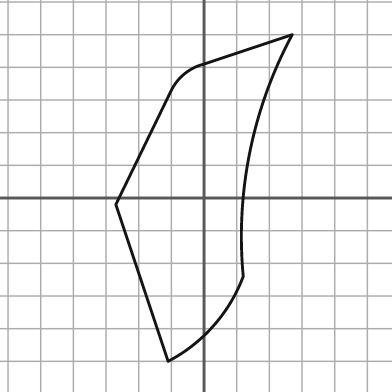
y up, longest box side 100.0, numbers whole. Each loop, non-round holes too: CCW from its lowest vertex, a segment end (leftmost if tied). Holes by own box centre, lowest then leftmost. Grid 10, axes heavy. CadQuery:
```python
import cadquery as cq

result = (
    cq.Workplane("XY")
    .moveTo(-11.0, -50.0)
    .threePointArc((3.0, -39.0), (12.0, -24.0))
    .threePointArc((14.0, 14.0), (27.0, 50.0))
    .lineTo(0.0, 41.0)
    .threePointArc((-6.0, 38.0), (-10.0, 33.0))
    .lineTo(-27.0, -2.0)
    .close()
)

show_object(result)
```